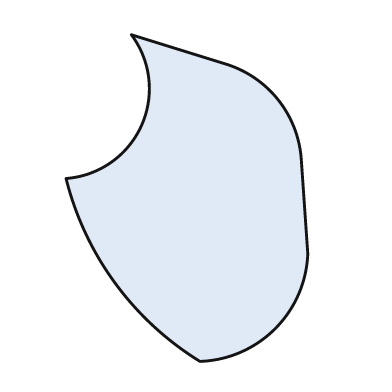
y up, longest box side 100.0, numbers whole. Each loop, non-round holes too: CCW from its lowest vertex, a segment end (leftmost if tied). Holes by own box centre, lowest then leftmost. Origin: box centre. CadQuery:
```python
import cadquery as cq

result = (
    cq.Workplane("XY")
    .moveTo(4.0, -50.0)
    .threePointArc((27.0, -40.0), (37.0, -17.0))
    .lineTo(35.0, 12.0)
    .threePointArc((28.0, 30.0), (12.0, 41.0))
    .lineTo(-17.0, 50.0)
    .threePointArc((-14.0, 22.0), (-37.0, 6.0))
    .threePointArc((-22.0, -26.0), (4.0, -50.0))
    .close()
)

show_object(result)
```